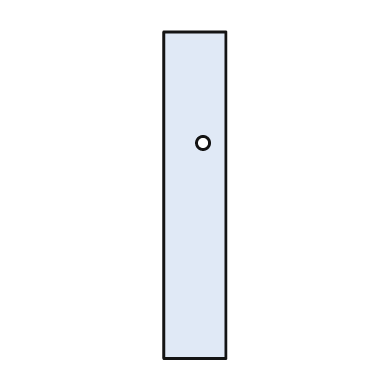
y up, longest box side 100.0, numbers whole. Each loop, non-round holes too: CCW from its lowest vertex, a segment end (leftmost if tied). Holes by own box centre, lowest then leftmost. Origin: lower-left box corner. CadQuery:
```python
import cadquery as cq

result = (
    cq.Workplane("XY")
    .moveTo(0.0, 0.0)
    .lineTo(19.0, 0.0)
    .lineTo(19.0, 100.0)
    .lineTo(0.0, 100.0)
    .close()
    .moveTo(12.0, 66.0)
    .circle(2.0)
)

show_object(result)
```